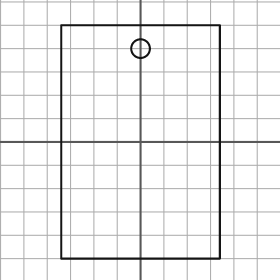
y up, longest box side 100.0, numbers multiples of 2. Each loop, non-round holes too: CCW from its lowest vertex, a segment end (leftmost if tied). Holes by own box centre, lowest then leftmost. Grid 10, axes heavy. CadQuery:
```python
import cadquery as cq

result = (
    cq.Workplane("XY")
    .moveTo(-34.0, -50.0)
    .lineTo(34.0, -50.0)
    .lineTo(34.0, 50.0)
    .lineTo(-34.0, 50.0)
    .close()
    .moveTo(0.0, 40.0)
    .circle(4.0)
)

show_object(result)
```